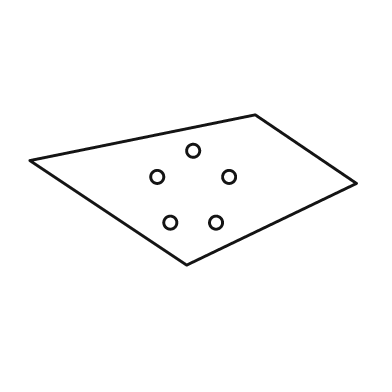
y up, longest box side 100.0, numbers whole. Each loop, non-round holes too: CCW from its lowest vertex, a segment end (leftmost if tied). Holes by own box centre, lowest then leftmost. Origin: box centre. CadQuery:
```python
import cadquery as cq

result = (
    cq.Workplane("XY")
    .moveTo(-2.0, -23.0)
    .lineTo(50.0, 2.0)
    .lineTo(19.0, 23.0)
    .lineTo(-50.0, 9.0)
    .close()
    .moveTo(-7.0, -10.0)
    .circle(2.0)
    .moveTo(7.0, -10.0)
    .circle(2.0)
    .moveTo(-11.0, 4.0)
    .circle(2.0)
    .moveTo(11.0, 4.0)
    .circle(2.0)
    .moveTo(0.0, 12.0)
    .circle(2.0)
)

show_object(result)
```